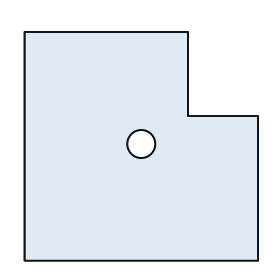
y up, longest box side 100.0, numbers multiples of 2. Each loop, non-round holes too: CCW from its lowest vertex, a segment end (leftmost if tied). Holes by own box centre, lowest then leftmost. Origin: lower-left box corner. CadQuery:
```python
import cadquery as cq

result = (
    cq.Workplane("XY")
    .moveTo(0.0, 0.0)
    .lineTo(100.0, 0.0)
    .lineTo(100.0, 62.0)
    .lineTo(70.0, 62.0)
    .lineTo(70.0, 98.0)
    .lineTo(0.0, 98.0)
    .close()
    .moveTo(50.0, 50.0)
    .circle(6.0)
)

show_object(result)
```